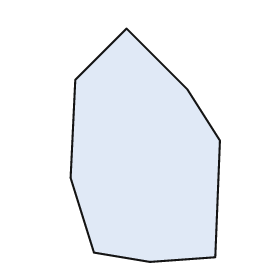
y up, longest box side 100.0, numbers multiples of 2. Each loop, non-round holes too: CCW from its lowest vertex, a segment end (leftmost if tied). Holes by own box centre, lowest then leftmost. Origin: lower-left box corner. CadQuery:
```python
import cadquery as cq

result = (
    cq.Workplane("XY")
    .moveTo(34.0, 0.0)
    .lineTo(62.0, 2.0)
    .lineTo(64.0, 52.0)
    .lineTo(50.0, 74.0)
    .lineTo(24.0, 100.0)
    .lineTo(2.0, 78.0)
    .lineTo(0.0, 36.0)
    .lineTo(10.0, 4.0)
    .close()
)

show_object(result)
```